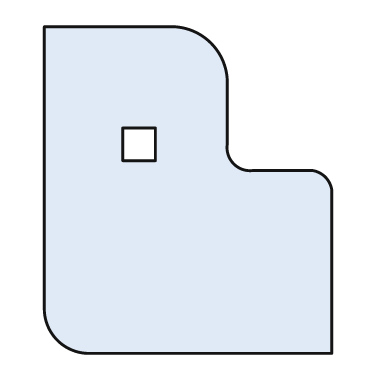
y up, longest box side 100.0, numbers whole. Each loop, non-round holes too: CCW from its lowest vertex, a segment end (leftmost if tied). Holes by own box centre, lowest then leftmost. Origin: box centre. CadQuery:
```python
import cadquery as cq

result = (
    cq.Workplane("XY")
    .moveTo(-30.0, -50.0)
    .lineTo(44.0, -50.0)
    .lineTo(44.0, 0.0)
    .threePointArc((42.0, 4.0), (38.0, 6.0))
    .lineTo(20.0, 6.0)
    .threePointArc((14.0, 8.0), (12.0, 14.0))
    .lineTo(12.0, 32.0)
    .threePointArc((7.0, 45.0), (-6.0, 50.0))
    .lineTo(-44.0, 50.0)
    .lineTo(-44.0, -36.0)
    .threePointArc((-40.0, -46.0), (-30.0, -50.0))
    .close()
    .moveTo(-20.0, 9.0)
    .lineTo(-10.0, 9.0)
    .lineTo(-10.0, 19.0)
    .lineTo(-20.0, 19.0)
    .close()
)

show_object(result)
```